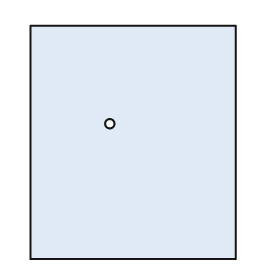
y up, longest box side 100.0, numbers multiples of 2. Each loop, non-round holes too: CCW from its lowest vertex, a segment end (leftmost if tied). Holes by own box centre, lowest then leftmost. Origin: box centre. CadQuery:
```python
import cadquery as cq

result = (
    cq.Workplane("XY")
    .moveTo(-44.0, -50.0)
    .lineTo(44.0, -50.0)
    .lineTo(44.0, 50.0)
    .lineTo(-44.0, 50.0)
    .close()
    .moveTo(-10.0, 8.0)
    .circle(2.0)
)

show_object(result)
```